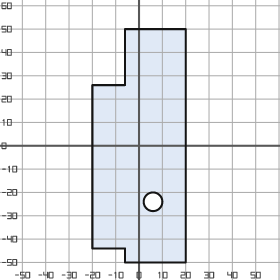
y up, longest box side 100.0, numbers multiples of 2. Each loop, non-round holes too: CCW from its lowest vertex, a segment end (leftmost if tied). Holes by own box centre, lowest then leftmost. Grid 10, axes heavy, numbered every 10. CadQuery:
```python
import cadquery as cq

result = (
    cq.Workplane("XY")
    .moveTo(-6.0, -50.0)
    .lineTo(20.0, -50.0)
    .lineTo(20.0, 50.0)
    .lineTo(-6.0, 50.0)
    .lineTo(-6.0, 26.0)
    .lineTo(-20.0, 26.0)
    .lineTo(-20.0, -44.0)
    .lineTo(-6.0, -44.0)
    .close()
    .moveTo(6.0, -24.0)
    .circle(4.0)
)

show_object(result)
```